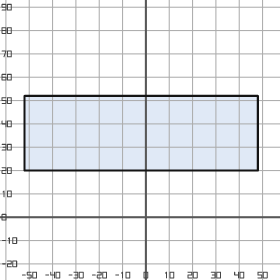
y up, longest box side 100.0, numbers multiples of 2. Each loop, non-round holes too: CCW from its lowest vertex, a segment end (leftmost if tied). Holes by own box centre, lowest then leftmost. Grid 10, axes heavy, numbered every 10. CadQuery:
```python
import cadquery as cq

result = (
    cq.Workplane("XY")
    .moveTo(-52.0, 20.0)
    .lineTo(48.0, 20.0)
    .lineTo(48.0, 52.0)
    .lineTo(-52.0, 52.0)
    .close()
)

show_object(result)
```